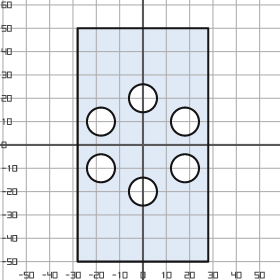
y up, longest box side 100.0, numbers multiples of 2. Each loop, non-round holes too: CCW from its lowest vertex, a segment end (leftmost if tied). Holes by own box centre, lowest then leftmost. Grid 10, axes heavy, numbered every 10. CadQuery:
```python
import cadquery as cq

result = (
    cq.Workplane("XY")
    .moveTo(-28.0, -50.0)
    .lineTo(28.0, -50.0)
    .lineTo(28.0, 50.0)
    .lineTo(-28.0, 50.0)
    .close()
    .moveTo(0.0, -20.0)
    .circle(6.0)
    .moveTo(-18.0, -10.0)
    .circle(6.0)
    .moveTo(18.0, -10.0)
    .circle(6.0)
    .moveTo(-18.0, 10.0)
    .circle(6.0)
    .moveTo(18.0, 10.0)
    .circle(6.0)
    .moveTo(0.0, 20.0)
    .circle(6.0)
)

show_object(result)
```